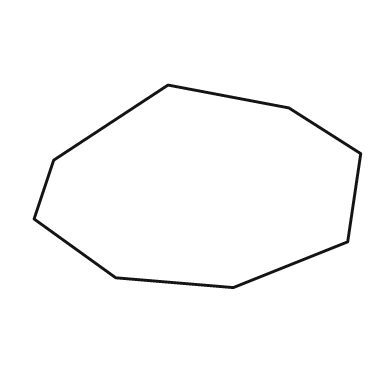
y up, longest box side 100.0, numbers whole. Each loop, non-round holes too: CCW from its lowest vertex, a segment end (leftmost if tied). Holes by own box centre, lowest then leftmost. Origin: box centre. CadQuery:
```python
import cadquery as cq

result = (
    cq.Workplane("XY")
    .moveTo(11.0, -31.0)
    .lineTo(46.0, -17.0)
    .lineTo(50.0, 10.0)
    .lineTo(28.0, 24.0)
    .lineTo(-9.0, 31.0)
    .lineTo(-44.0, 8.0)
    .lineTo(-50.0, -10.0)
    .lineTo(-25.0, -28.0)
    .close()
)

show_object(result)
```